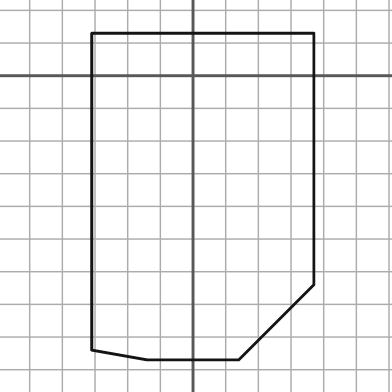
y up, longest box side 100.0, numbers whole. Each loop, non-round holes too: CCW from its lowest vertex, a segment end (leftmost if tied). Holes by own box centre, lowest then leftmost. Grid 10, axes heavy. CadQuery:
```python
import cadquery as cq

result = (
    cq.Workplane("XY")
    .moveTo(-14.0, -87.0)
    .lineTo(14.0, -87.0)
    .lineTo(37.0, -64.0)
    .lineTo(37.0, 13.0)
    .lineTo(-31.0, 13.0)
    .lineTo(-31.0, -84.0)
    .close()
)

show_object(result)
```